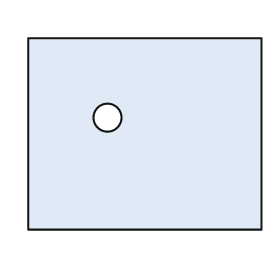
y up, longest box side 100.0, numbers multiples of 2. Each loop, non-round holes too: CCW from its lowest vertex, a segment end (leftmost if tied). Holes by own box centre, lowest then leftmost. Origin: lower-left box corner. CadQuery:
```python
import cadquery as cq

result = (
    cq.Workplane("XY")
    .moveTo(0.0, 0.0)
    .lineTo(100.0, 0.0)
    .lineTo(100.0, 82.0)
    .lineTo(0.0, 82.0)
    .close()
    .moveTo(34.0, 48.0)
    .circle(6.0)
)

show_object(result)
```